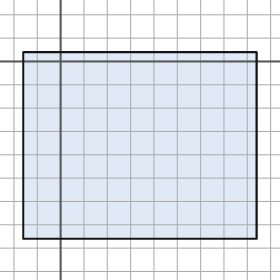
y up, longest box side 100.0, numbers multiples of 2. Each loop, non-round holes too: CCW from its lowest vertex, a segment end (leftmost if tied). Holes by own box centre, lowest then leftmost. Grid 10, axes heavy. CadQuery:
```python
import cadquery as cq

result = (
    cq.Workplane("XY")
    .moveTo(-16.0, -76.0)
    .lineTo(84.0, -76.0)
    .lineTo(84.0, 4.0)
    .lineTo(-16.0, 4.0)
    .close()
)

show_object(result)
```